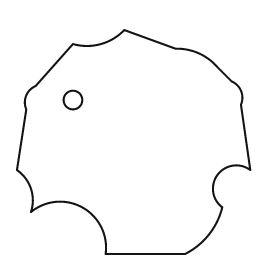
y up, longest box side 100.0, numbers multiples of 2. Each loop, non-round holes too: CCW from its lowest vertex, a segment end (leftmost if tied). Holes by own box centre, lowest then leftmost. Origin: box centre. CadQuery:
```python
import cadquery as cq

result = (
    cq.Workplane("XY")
    .moveTo(-12.0, -48.0)
    .lineTo(22.0, -48.0)
    .threePointArc((32.0, -40.0), (38.0, -28.0))
    .threePointArc((36.0, -14.0), (50.0, -12.0))
    .lineTo(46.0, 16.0)
    .threePointArc((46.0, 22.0), (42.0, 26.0))
    .lineTo(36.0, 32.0)
    .threePointArc((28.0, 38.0), (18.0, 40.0))
    .lineTo(-4.0, 48.0)
    .threePointArc((-14.0, 42.0), (-26.0, 42.0))
    .lineTo(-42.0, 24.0)
    .threePointArc((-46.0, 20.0), (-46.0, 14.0))
    .lineTo(-50.0, -12.0)
    .threePointArc((-44.0, -20.0), (-44.0, -30.0))
    .threePointArc((-22.0, -28.0), (-12.0, -48.0))
    .close()
    .moveTo(-26.0, 18.0)
    .circle(4.0)
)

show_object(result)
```